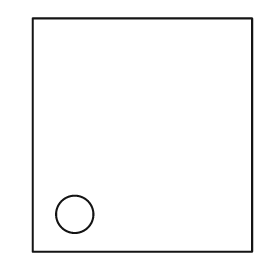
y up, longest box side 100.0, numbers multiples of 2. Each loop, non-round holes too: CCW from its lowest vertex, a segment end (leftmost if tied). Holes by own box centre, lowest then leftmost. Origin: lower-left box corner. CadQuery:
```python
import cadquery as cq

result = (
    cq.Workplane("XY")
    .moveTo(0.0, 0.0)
    .lineTo(94.0, 0.0)
    .lineTo(94.0, 100.0)
    .lineTo(0.0, 100.0)
    .close()
    .moveTo(18.0, 16.0)
    .circle(8.0)
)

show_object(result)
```